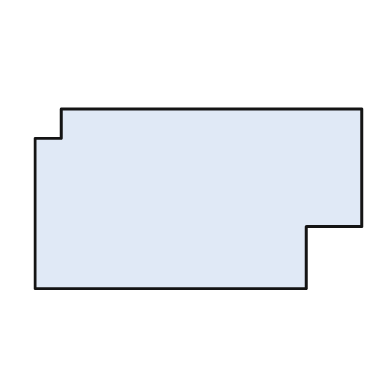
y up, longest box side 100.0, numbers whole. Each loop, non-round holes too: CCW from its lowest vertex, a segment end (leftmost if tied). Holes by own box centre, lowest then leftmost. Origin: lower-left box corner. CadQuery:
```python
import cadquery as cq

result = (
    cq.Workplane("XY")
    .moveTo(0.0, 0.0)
    .lineTo(83.0, 0.0)
    .lineTo(83.0, 19.0)
    .lineTo(100.0, 19.0)
    .lineTo(100.0, 55.0)
    .lineTo(8.0, 55.0)
    .lineTo(8.0, 46.0)
    .lineTo(0.0, 46.0)
    .close()
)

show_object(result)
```